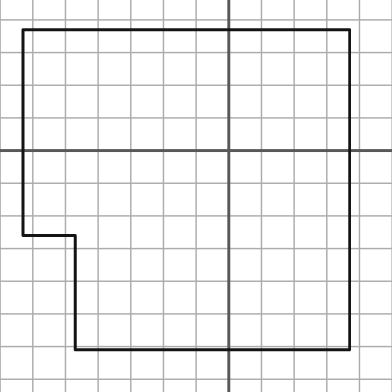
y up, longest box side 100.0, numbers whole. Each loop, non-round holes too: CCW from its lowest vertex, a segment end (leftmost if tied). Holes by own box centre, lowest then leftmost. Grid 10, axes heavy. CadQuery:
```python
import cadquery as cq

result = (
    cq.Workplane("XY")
    .moveTo(-47.0, -61.0)
    .lineTo(37.0, -61.0)
    .lineTo(37.0, 37.0)
    .lineTo(-63.0, 37.0)
    .lineTo(-63.0, -26.0)
    .lineTo(-47.0, -26.0)
    .close()
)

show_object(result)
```